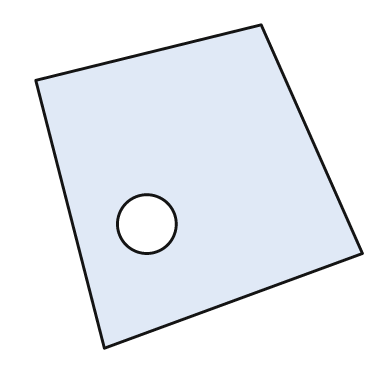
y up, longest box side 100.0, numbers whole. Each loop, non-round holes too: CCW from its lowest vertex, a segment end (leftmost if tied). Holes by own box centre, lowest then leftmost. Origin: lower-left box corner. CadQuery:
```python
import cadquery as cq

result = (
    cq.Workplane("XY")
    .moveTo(21.0, 0.0)
    .lineTo(100.0, 29.0)
    .lineTo(69.0, 99.0)
    .lineTo(0.0, 82.0)
    .close()
    .moveTo(34.0, 38.0)
    .circle(9.0)
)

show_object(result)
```